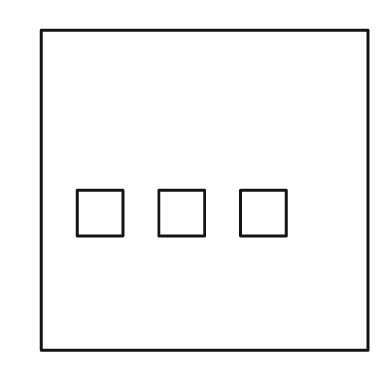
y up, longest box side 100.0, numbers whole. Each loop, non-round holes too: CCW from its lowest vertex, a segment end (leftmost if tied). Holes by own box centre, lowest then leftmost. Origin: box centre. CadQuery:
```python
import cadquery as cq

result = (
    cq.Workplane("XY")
    .moveTo(-50.0, -49.0)
    .lineTo(50.0, -49.0)
    .lineTo(50.0, 49.0)
    .lineTo(-50.0, 49.0)
    .close()
    .moveTo(-39.0, -14.0)
    .lineTo(-25.0, -14.0)
    .lineTo(-25.0, 0.0)
    .lineTo(-39.0, 0.0)
    .close()
    .moveTo(-14.0, -14.0)
    .lineTo(0.0, -14.0)
    .lineTo(0.0, 0.0)
    .lineTo(-14.0, 0.0)
    .close()
    .moveTo(11.0, -14.0)
    .lineTo(25.0, -14.0)
    .lineTo(25.0, 0.0)
    .lineTo(11.0, 0.0)
    .close()
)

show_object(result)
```